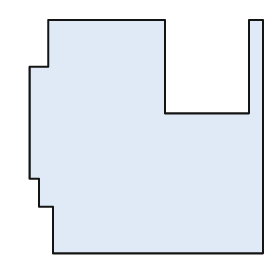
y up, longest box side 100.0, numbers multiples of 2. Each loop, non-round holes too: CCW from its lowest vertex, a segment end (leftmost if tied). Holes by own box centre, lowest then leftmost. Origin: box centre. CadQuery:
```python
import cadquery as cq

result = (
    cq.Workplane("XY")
    .moveTo(-40.0, -50.0)
    .lineTo(50.0, -50.0)
    .lineTo(50.0, 50.0)
    .lineTo(44.0, 50.0)
    .lineTo(44.0, 10.0)
    .lineTo(8.0, 10.0)
    .lineTo(8.0, 50.0)
    .lineTo(-42.0, 50.0)
    .lineTo(-42.0, 30.0)
    .lineTo(-50.0, 30.0)
    .lineTo(-50.0, -18.0)
    .lineTo(-46.0, -18.0)
    .lineTo(-46.0, -30.0)
    .lineTo(-40.0, -30.0)
    .close()
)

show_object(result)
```